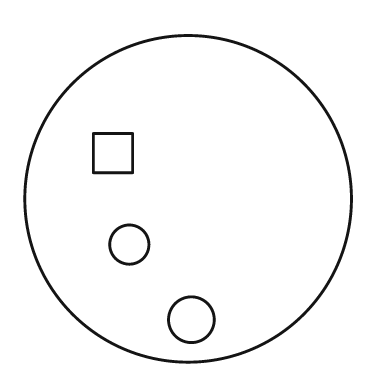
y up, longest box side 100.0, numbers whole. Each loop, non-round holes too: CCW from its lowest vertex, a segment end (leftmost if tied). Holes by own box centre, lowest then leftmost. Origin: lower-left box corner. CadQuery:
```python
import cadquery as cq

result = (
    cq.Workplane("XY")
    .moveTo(50.0, 50.0)
    .circle(50.0)
    .moveTo(51.0, 13.0)
    .circle(7.0)
    .moveTo(32.0, 36.0)
    .circle(6.0)
    .moveTo(21.0, 58.0)
    .lineTo(33.0, 58.0)
    .lineTo(33.0, 70.0)
    .lineTo(21.0, 70.0)
    .close()
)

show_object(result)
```